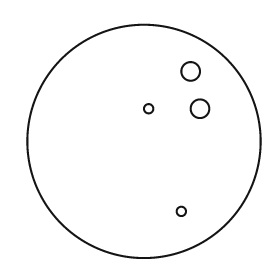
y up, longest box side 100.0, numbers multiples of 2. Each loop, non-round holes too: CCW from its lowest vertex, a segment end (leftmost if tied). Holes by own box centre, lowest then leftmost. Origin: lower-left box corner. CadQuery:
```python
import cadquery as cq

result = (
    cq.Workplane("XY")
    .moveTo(50.0, 50.0)
    .circle(50.0)
    .moveTo(66.0, 20.0)
    .circle(2.0)
    .moveTo(52.0, 64.0)
    .circle(2.0)
    .moveTo(74.0, 64.0)
    .circle(4.0)
    .moveTo(70.0, 80.0)
    .circle(4.0)
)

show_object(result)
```